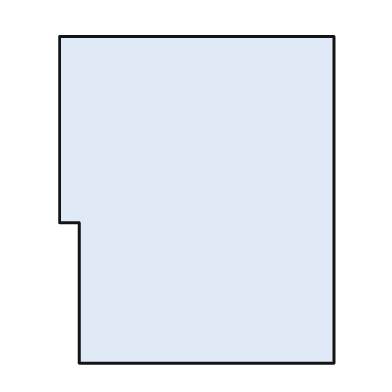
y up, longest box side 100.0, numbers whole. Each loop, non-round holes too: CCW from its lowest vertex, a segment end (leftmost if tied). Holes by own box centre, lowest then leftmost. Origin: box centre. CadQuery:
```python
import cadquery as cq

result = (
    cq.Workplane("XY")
    .moveTo(-36.0, -50.0)
    .lineTo(42.0, -50.0)
    .lineTo(42.0, 50.0)
    .lineTo(-42.0, 50.0)
    .lineTo(-42.0, -7.0)
    .lineTo(-36.0, -7.0)
    .close()
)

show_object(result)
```